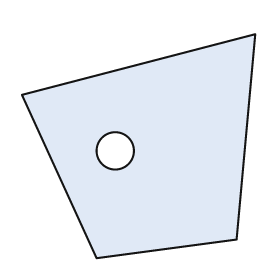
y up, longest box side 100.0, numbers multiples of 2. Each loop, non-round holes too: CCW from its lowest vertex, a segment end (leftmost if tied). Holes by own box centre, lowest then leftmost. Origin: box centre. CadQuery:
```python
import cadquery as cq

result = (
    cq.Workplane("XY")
    .moveTo(-18.0, -48.0)
    .lineTo(42.0, -40.0)
    .lineTo(50.0, 48.0)
    .lineTo(-50.0, 22.0)
    .close()
    .moveTo(-10.0, -2.0)
    .circle(8.0)
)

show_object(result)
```